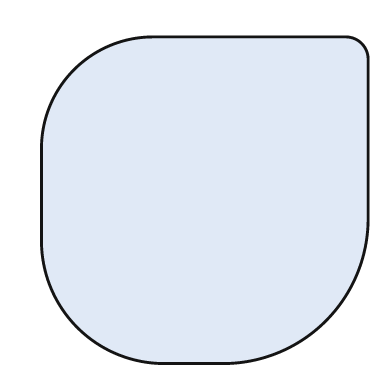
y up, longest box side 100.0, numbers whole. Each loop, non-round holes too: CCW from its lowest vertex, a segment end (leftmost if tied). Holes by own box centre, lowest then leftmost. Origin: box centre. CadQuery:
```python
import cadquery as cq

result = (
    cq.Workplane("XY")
    .moveTo(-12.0, -50.0)
    .lineTo(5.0, -50.0)
    .threePointArc((37.0, -37.0), (50.0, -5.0))
    .lineTo(50.0, 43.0)
    .threePointArc((48.0, 48.0), (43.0, 50.0))
    .lineTo(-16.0, 50.0)
    .threePointArc((-40.0, 40.0), (-50.0, 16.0))
    .lineTo(-50.0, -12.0)
    .threePointArc((-39.0, -39.0), (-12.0, -50.0))
    .close()
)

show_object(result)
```